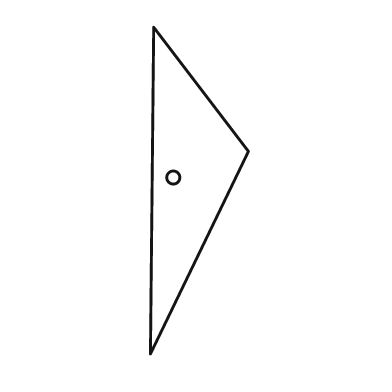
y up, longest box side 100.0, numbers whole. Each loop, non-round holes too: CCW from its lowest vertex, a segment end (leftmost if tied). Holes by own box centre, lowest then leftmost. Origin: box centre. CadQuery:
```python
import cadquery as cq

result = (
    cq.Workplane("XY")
    .moveTo(-15.0, -50.0)
    .lineTo(15.0, 12.0)
    .lineTo(-14.0, 50.0)
    .close()
    .moveTo(-8.0, 4.0)
    .circle(2.0)
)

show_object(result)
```